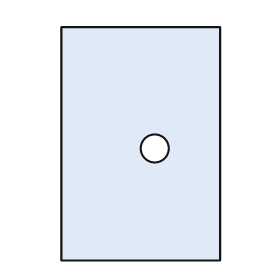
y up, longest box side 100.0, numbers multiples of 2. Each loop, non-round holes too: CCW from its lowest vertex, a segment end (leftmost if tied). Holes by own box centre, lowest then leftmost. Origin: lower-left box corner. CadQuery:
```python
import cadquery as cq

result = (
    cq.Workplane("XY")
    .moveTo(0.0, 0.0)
    .lineTo(68.0, 0.0)
    .lineTo(68.0, 100.0)
    .lineTo(0.0, 100.0)
    .close()
    .moveTo(40.0, 48.0)
    .circle(6.0)
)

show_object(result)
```